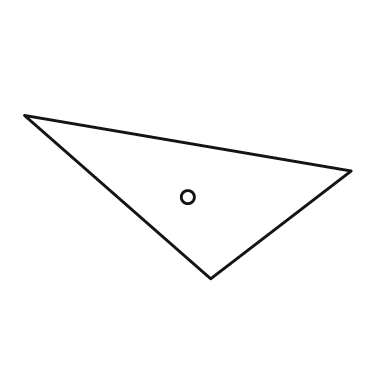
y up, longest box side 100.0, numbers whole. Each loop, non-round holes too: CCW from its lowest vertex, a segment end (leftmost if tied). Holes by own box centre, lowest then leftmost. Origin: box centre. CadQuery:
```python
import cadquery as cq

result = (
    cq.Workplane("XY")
    .moveTo(7.0, -25.0)
    .lineTo(50.0, 8.0)
    .lineTo(-50.0, 25.0)
    .close()
    .moveTo(0.0, 0.0)
    .circle(2.0)
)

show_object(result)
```